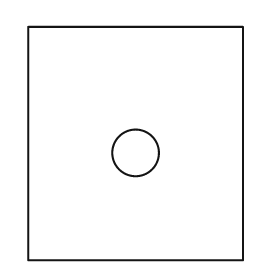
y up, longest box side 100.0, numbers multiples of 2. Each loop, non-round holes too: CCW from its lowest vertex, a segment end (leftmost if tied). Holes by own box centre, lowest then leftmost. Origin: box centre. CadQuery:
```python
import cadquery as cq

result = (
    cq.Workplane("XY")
    .moveTo(-46.0, -50.0)
    .lineTo(46.0, -50.0)
    .lineTo(46.0, 50.0)
    .lineTo(-46.0, 50.0)
    .close()
    .moveTo(0.0, -4.0)
    .circle(10.0)
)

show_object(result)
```